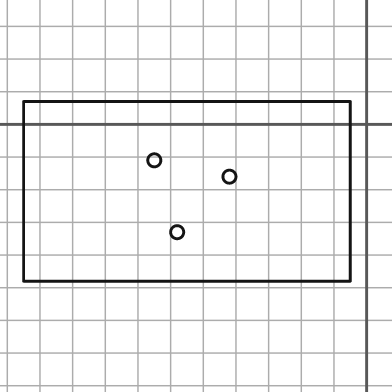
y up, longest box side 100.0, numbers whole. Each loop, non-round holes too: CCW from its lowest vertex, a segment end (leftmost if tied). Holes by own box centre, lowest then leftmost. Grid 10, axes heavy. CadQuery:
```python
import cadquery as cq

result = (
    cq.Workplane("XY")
    .moveTo(-105.0, -48.0)
    .lineTo(-5.0, -48.0)
    .lineTo(-5.0, 7.0)
    .lineTo(-105.0, 7.0)
    .close()
    .moveTo(-58.0, -33.0)
    .circle(2.0)
    .moveTo(-42.0, -16.0)
    .circle(2.0)
    .moveTo(-65.0, -11.0)
    .circle(2.0)
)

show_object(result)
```